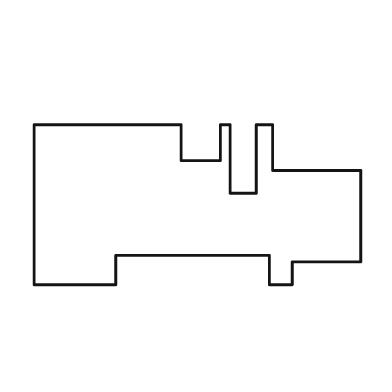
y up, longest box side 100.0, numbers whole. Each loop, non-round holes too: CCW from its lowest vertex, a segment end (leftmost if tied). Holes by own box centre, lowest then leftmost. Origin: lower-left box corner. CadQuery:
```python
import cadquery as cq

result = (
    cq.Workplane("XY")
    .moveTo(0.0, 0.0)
    .lineTo(25.0, 0.0)
    .lineTo(25.0, 9.0)
    .lineTo(72.0, 9.0)
    .lineTo(72.0, 0.0)
    .lineTo(79.0, 0.0)
    .lineTo(79.0, 7.0)
    .lineTo(100.0, 7.0)
    .lineTo(100.0, 35.0)
    .lineTo(73.0, 35.0)
    .lineTo(73.0, 49.0)
    .lineTo(68.0, 49.0)
    .lineTo(68.0, 28.0)
    .lineTo(60.0, 28.0)
    .lineTo(60.0, 49.0)
    .lineTo(57.0, 49.0)
    .lineTo(57.0, 38.0)
    .lineTo(45.0, 38.0)
    .lineTo(45.0, 49.0)
    .lineTo(0.0, 49.0)
    .close()
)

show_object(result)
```